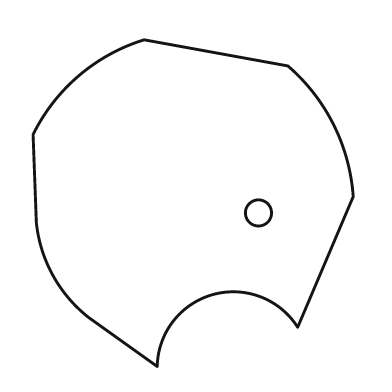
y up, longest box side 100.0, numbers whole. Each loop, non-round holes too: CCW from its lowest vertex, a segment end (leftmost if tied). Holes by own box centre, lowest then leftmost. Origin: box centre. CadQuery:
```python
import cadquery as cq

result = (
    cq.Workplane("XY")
    .moveTo(-11.0, -50.0)
    .threePointArc((6.0, -28.0), (32.0, -38.0))
    .lineTo(49.0, 2.0)
    .threePointArc((43.0, 24.0), (29.0, 42.0))
    .lineTo(-15.0, 50.0)
    .threePointArc((-35.0, 39.0), (-49.0, 21.0))
    .lineTo(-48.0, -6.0)
    .threePointArc((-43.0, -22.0), (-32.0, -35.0))
    .close()
    .moveTo(20.0, -3.0)
    .circle(4.0)
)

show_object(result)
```